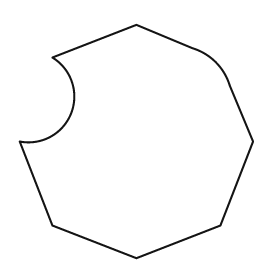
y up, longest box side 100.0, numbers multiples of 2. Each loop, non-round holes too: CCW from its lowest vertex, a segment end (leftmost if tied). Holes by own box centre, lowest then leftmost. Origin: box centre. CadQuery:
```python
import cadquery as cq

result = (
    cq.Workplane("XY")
    .moveTo(0.0, -50.0)
    .lineTo(36.0, -36.0)
    .lineTo(50.0, 0.0)
    .lineTo(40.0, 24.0)
    .threePointArc((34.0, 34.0), (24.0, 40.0))
    .lineTo(0.0, 50.0)
    .lineTo(-36.0, 36.0)
    .threePointArc((-28.0, 12.0), (-50.0, 0.0))
    .lineTo(-36.0, -36.0)
    .close()
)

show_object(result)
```